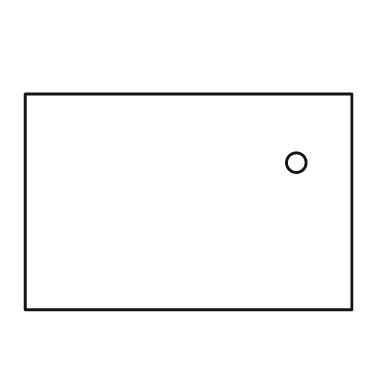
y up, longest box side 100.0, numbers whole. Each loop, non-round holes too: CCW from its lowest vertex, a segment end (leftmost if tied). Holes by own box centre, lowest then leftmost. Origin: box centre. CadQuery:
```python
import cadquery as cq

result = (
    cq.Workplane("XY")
    .moveTo(-50.0, -33.0)
    .lineTo(50.0, -33.0)
    .lineTo(50.0, 33.0)
    .lineTo(-50.0, 33.0)
    .close()
    .moveTo(33.0, 12.0)
    .circle(3.0)
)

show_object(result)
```